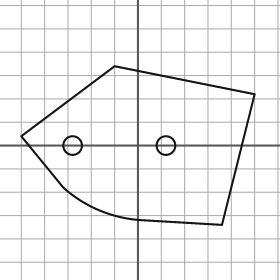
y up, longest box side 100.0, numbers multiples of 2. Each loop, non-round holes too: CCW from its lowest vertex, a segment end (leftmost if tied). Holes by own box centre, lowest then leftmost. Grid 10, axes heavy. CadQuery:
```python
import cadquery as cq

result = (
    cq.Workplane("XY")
    .moveTo(36.0, -34.0)
    .lineTo(50.0, 22.0)
    .lineTo(-10.0, 34.0)
    .lineTo(-50.0, 4.0)
    .lineTo(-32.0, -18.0)
    .threePointArc((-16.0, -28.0), (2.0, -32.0))
    .close()
    .moveTo(-28.0, 0.0)
    .circle(4.0)
    .moveTo(12.0, 0.0)
    .circle(4.0)
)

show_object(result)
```